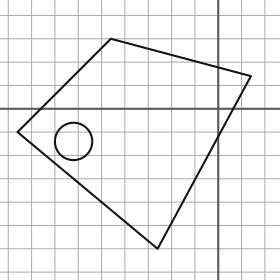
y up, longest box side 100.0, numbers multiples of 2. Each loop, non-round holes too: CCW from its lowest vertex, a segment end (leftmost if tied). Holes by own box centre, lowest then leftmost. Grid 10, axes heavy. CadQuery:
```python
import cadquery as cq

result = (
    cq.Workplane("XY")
    .moveTo(-26.0, -60.0)
    .lineTo(14.0, 14.0)
    .lineTo(-46.0, 30.0)
    .lineTo(-86.0, -10.0)
    .close()
    .moveTo(-62.0, -14.0)
    .circle(8.0)
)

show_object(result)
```